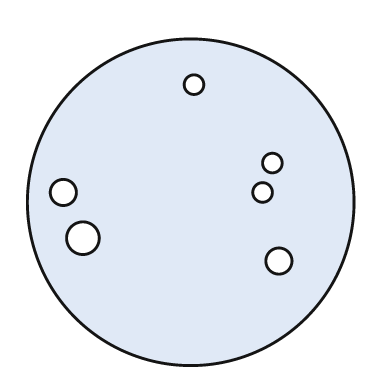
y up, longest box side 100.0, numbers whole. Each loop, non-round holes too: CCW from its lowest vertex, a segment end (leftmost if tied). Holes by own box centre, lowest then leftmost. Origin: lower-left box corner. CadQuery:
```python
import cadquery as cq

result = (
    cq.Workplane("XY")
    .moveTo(50.0, 50.0)
    .circle(50.0)
    .moveTo(77.0, 32.0)
    .circle(4.0)
    .moveTo(17.0, 39.0)
    .circle(5.0)
    .moveTo(11.0, 53.0)
    .circle(4.0)
    .moveTo(72.0, 53.0)
    .circle(3.0)
    .moveTo(75.0, 62.0)
    .circle(3.0)
    .moveTo(51.0, 86.0)
    .circle(3.0)
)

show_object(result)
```